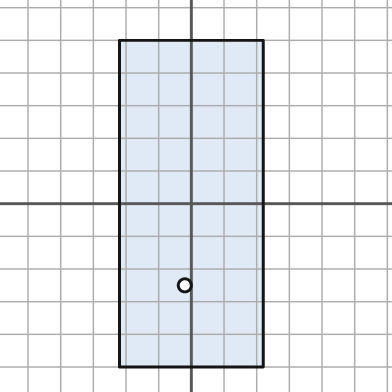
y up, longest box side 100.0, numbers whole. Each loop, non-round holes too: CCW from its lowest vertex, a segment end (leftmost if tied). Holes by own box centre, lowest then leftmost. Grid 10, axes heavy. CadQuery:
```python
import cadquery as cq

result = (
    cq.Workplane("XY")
    .moveTo(-22.0, -50.0)
    .lineTo(22.0, -50.0)
    .lineTo(22.0, 50.0)
    .lineTo(-22.0, 50.0)
    .close()
    .moveTo(-2.0, -25.0)
    .circle(2.0)
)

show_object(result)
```